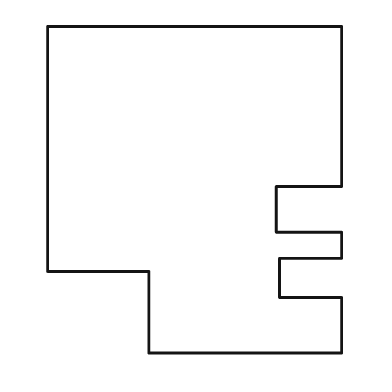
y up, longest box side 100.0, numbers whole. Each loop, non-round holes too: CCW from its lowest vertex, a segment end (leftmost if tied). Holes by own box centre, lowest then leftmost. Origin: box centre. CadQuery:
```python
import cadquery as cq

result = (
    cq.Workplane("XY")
    .moveTo(-14.0, -50.0)
    .lineTo(45.0, -50.0)
    .lineTo(45.0, -33.0)
    .lineTo(26.0, -33.0)
    .lineTo(26.0, -21.0)
    .lineTo(45.0, -21.0)
    .lineTo(45.0, -13.0)
    .lineTo(25.0, -13.0)
    .lineTo(25.0, 1.0)
    .lineTo(45.0, 1.0)
    .lineTo(45.0, 50.0)
    .lineTo(-45.0, 50.0)
    .lineTo(-45.0, -25.0)
    .lineTo(-14.0, -25.0)
    .close()
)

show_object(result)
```